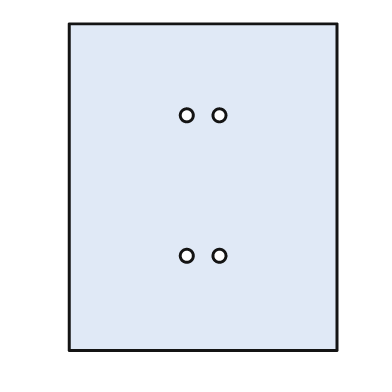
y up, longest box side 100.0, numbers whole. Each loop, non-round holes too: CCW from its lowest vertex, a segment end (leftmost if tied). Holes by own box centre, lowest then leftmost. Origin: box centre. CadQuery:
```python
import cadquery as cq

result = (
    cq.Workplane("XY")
    .moveTo(-41.0, -50.0)
    .lineTo(41.0, -50.0)
    .lineTo(41.0, 50.0)
    .lineTo(-41.0, 50.0)
    .close()
    .moveTo(-5.0, -21.0)
    .circle(2.0)
    .moveTo(5.0, -21.0)
    .circle(2.0)
    .moveTo(-5.0, 22.0)
    .circle(2.0)
    .moveTo(5.0, 22.0)
    .circle(2.0)
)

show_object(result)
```